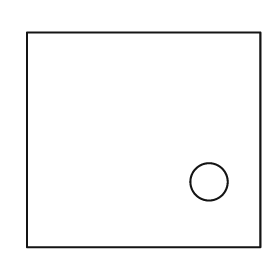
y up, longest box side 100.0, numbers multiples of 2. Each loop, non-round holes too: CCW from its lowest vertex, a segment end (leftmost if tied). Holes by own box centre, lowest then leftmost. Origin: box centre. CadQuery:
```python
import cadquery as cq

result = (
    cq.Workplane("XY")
    .moveTo(-50.0, -46.0)
    .lineTo(50.0, -46.0)
    .lineTo(50.0, 46.0)
    .lineTo(-50.0, 46.0)
    .close()
    .moveTo(28.0, -18.0)
    .circle(8.0)
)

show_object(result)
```